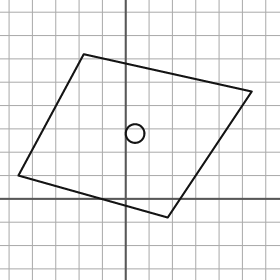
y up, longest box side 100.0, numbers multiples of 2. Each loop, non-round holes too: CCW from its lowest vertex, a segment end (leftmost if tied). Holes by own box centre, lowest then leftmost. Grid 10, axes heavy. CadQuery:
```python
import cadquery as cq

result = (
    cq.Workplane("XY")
    .moveTo(18.0, -8.0)
    .lineTo(54.0, 46.0)
    .lineTo(-18.0, 62.0)
    .lineTo(-46.0, 10.0)
    .close()
    .moveTo(4.0, 28.0)
    .circle(4.0)
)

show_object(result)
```